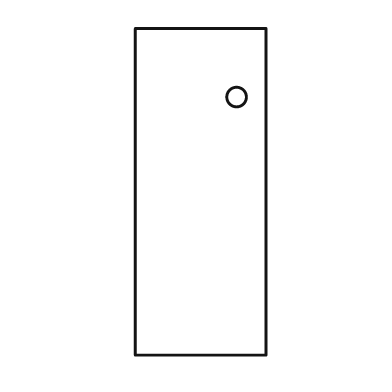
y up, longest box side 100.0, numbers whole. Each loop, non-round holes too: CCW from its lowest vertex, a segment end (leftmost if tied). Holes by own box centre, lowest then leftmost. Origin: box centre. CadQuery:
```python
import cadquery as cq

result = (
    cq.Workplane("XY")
    .moveTo(-20.0, -50.0)
    .lineTo(20.0, -50.0)
    .lineTo(20.0, 50.0)
    .lineTo(-20.0, 50.0)
    .close()
    .moveTo(11.0, 29.0)
    .circle(3.0)
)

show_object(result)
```